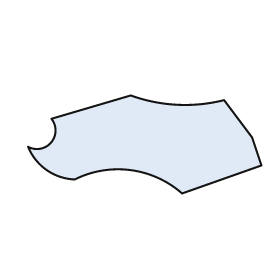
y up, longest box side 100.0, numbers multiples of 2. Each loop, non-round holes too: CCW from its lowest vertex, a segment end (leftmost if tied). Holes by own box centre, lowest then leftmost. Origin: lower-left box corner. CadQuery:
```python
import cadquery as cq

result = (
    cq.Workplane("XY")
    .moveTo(66.0, 0.0)
    .lineTo(100.0, 12.0)
    .lineTo(96.0, 24.0)
    .lineTo(84.0, 40.0)
    .threePointArc((64.0, 38.0), (44.0, 42.0))
    .lineTo(10.0, 32.0)
    .threePointArc((10.0, 22.0), (0.0, 20.0))
    .threePointArc((8.0, 10.0), (20.0, 6.0))
    .threePointArc((44.0, 10.0), (66.0, 0.0))
    .close()
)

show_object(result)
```